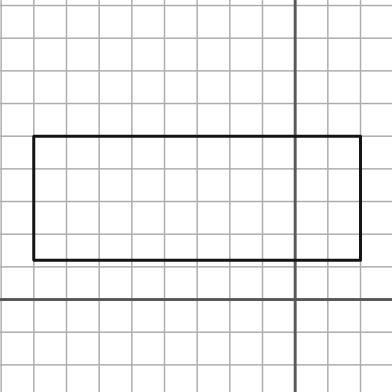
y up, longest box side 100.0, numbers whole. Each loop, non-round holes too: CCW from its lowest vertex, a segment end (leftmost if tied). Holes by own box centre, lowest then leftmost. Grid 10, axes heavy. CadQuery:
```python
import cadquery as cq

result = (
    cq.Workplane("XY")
    .moveTo(-80.0, 12.0)
    .lineTo(20.0, 12.0)
    .lineTo(20.0, 50.0)
    .lineTo(-80.0, 50.0)
    .close()
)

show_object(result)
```